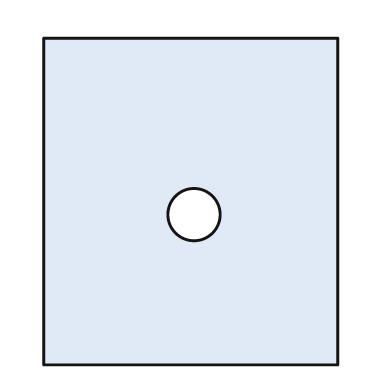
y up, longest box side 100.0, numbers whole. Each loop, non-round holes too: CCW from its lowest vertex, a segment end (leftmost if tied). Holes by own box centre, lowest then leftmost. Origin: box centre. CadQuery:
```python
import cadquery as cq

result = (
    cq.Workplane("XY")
    .moveTo(-45.0, -50.0)
    .lineTo(45.0, -50.0)
    .lineTo(45.0, 50.0)
    .lineTo(-45.0, 50.0)
    .close()
    .moveTo(1.0, -4.0)
    .circle(8.0)
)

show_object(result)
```